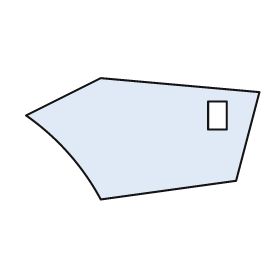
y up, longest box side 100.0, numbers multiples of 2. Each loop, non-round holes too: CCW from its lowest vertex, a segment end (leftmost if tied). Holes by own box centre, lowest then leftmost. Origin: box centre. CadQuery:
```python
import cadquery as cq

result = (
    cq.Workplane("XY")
    .moveTo(-18.0, -26.0)
    .lineTo(40.0, -18.0)
    .lineTo(50.0, 20.0)
    .lineTo(-18.0, 26.0)
    .lineTo(-50.0, 10.0)
    .threePointArc((-32.0, -6.0), (-18.0, -26.0))
    .close()
    .moveTo(28.0, 4.0)
    .lineTo(36.0, 4.0)
    .lineTo(36.0, 16.0)
    .lineTo(28.0, 16.0)
    .close()
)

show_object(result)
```